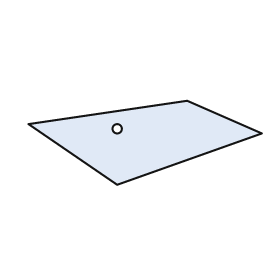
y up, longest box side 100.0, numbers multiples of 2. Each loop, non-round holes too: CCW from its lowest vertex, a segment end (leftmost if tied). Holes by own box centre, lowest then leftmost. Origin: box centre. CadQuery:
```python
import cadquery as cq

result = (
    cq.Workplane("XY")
    .moveTo(-12.0, -18.0)
    .lineTo(50.0, 4.0)
    .lineTo(18.0, 18.0)
    .lineTo(-50.0, 8.0)
    .close()
    .moveTo(-12.0, 6.0)
    .circle(2.0)
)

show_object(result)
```